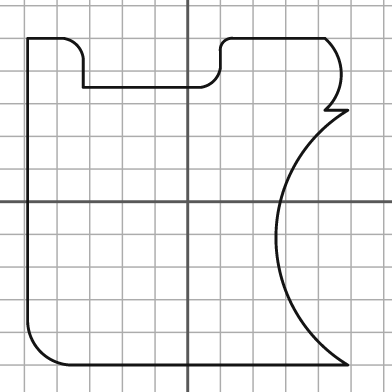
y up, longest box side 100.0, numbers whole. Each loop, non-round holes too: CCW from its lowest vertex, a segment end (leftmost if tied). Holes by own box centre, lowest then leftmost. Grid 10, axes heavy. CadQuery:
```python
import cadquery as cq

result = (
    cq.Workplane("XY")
    .moveTo(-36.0, -50.0)
    .lineTo(49.0, -50.0)
    .threePointArc((27.0, -11.0), (49.0, 28.0))
    .lineTo(42.0, 28.0)
    .threePointArc((47.0, 39.0), (42.0, 50.0))
    .lineTo(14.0, 50.0)
    .threePointArc((11.0, 49.0), (10.0, 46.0))
    .lineTo(10.0, 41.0)
    .threePointArc((8.0, 37.0), (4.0, 35.0))
    .lineTo(-32.0, 35.0)
    .lineTo(-32.0, 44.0)
    .threePointArc((-34.0, 48.0), (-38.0, 50.0))
    .lineTo(-49.0, 50.0)
    .lineTo(-49.0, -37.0)
    .threePointArc((-45.0, -46.0), (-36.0, -50.0))
    .close()
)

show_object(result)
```